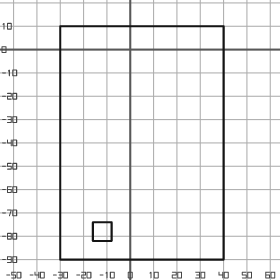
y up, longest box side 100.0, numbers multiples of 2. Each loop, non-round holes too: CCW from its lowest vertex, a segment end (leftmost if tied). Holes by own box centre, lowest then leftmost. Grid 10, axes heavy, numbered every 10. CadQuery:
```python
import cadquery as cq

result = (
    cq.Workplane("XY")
    .moveTo(-30.0, -90.0)
    .lineTo(40.0, -90.0)
    .lineTo(40.0, 10.0)
    .lineTo(-30.0, 10.0)
    .close()
    .moveTo(-16.0, -82.0)
    .lineTo(-8.0, -82.0)
    .lineTo(-8.0, -74.0)
    .lineTo(-16.0, -74.0)
    .close()
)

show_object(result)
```